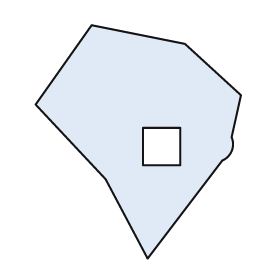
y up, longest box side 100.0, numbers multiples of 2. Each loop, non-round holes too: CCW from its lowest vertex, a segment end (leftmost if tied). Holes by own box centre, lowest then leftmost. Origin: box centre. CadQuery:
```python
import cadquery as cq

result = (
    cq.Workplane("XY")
    .moveTo(4.0, -50.0)
    .lineTo(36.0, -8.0)
    .threePointArc((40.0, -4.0), (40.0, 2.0))
    .lineTo(44.0, 20.0)
    .lineTo(20.0, 42.0)
    .lineTo(-20.0, 50.0)
    .lineTo(-44.0, 16.0)
    .lineTo(-14.0, -16.0)
    .close()
    .moveTo(2.0, -10.0)
    .lineTo(18.0, -10.0)
    .lineTo(18.0, 6.0)
    .lineTo(2.0, 6.0)
    .close()
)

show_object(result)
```